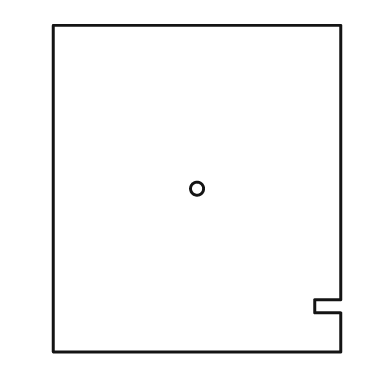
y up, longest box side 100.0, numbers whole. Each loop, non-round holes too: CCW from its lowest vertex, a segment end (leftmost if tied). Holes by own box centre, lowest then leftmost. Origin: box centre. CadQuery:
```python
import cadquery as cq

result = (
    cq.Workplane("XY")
    .moveTo(-44.0, -50.0)
    .lineTo(44.0, -50.0)
    .lineTo(44.0, -38.0)
    .lineTo(36.0, -38.0)
    .lineTo(36.0, -34.0)
    .lineTo(44.0, -34.0)
    .lineTo(44.0, 50.0)
    .lineTo(-44.0, 50.0)
    .close()
    .moveTo(0.0, 0.0)
    .circle(2.0)
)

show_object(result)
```